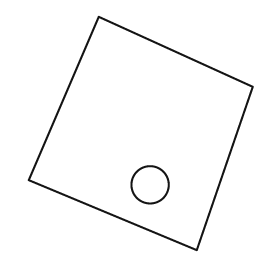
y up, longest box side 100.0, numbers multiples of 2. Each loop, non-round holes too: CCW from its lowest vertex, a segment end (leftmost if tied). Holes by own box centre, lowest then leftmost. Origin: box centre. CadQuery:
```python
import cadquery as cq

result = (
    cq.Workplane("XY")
    .moveTo(24.0, -50.0)
    .lineTo(48.0, 20.0)
    .lineTo(-18.0, 50.0)
    .lineTo(-48.0, -20.0)
    .close()
    .moveTo(4.0, -22.0)
    .circle(8.0)
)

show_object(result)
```